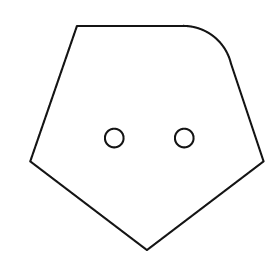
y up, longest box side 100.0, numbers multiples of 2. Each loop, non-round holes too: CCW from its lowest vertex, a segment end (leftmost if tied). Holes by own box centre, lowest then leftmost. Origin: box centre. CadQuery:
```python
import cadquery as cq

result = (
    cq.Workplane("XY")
    .moveTo(0.0, -48.0)
    .lineTo(50.0, -10.0)
    .lineTo(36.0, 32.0)
    .threePointArc((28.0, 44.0), (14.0, 48.0))
    .lineTo(-30.0, 48.0)
    .lineTo(-50.0, -10.0)
    .close()
    .moveTo(-14.0, 0.0)
    .circle(4.0)
    .moveTo(16.0, 0.0)
    .circle(4.0)
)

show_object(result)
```